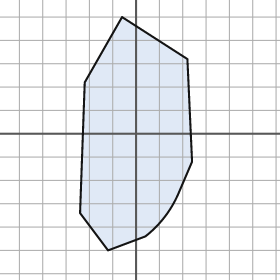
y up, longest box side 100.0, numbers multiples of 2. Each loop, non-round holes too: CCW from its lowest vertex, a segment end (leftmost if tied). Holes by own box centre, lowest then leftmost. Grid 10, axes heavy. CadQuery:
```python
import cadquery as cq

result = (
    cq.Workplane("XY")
    .moveTo(-12.0, -50.0)
    .lineTo(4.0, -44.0)
    .threePointArc((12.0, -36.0), (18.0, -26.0))
    .lineTo(24.0, -12.0)
    .lineTo(22.0, 32.0)
    .lineTo(-6.0, 50.0)
    .lineTo(-22.0, 22.0)
    .lineTo(-24.0, -34.0)
    .close()
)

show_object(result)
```